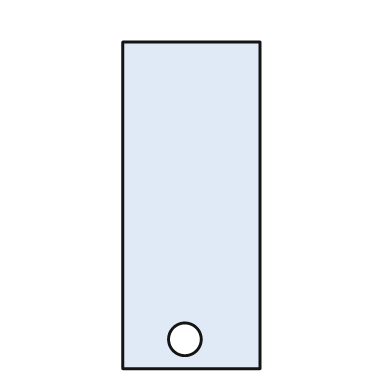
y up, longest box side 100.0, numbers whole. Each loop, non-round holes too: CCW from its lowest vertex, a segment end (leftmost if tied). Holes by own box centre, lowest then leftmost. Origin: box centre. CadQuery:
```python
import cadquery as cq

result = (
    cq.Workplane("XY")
    .moveTo(-21.0, -50.0)
    .lineTo(21.0, -50.0)
    .lineTo(21.0, 50.0)
    .lineTo(-21.0, 50.0)
    .close()
    .moveTo(-2.0, -41.0)
    .circle(5.0)
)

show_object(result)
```